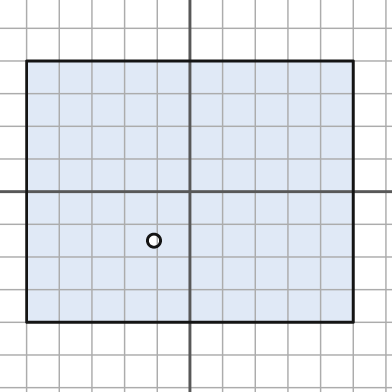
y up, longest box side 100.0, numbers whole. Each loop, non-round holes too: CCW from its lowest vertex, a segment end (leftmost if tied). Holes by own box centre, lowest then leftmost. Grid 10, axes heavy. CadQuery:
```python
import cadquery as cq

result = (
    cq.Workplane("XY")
    .moveTo(-50.0, -40.0)
    .lineTo(50.0, -40.0)
    .lineTo(50.0, 40.0)
    .lineTo(-50.0, 40.0)
    .close()
    .moveTo(-11.0, -15.0)
    .circle(2.0)
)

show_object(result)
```